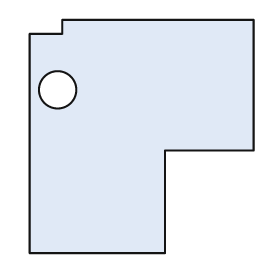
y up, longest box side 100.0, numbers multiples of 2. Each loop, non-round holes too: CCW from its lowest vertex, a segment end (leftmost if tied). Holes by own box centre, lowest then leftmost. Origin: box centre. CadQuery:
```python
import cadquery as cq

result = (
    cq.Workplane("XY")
    .moveTo(-48.0, -50.0)
    .lineTo(10.0, -50.0)
    .lineTo(10.0, -6.0)
    .lineTo(48.0, -6.0)
    .lineTo(48.0, 50.0)
    .lineTo(-34.0, 50.0)
    .lineTo(-34.0, 44.0)
    .lineTo(-48.0, 44.0)
    .close()
    .moveTo(-36.0, 20.0)
    .circle(8.0)
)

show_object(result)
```